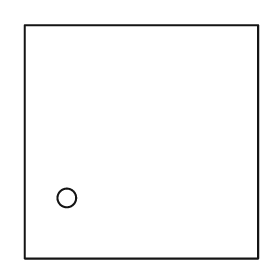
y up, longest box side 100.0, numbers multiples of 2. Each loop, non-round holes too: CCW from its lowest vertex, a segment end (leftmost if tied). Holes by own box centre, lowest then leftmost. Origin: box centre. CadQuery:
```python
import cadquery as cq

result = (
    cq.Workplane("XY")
    .moveTo(-50.0, -50.0)
    .lineTo(50.0, -50.0)
    .lineTo(50.0, 50.0)
    .lineTo(-50.0, 50.0)
    .close()
    .moveTo(-32.0, -24.0)
    .circle(4.0)
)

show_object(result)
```